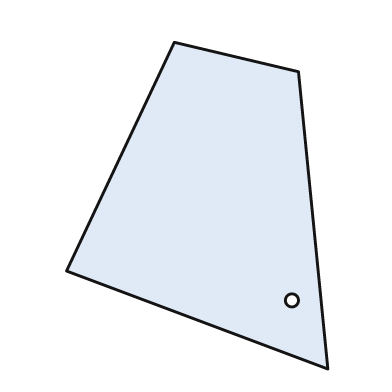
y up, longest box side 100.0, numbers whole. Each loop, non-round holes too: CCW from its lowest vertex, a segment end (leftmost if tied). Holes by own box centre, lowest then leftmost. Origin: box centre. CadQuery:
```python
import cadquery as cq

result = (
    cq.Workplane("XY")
    .moveTo(40.0, -50.0)
    .lineTo(31.0, 41.0)
    .lineTo(-7.0, 50.0)
    .lineTo(-40.0, -20.0)
    .close()
    .moveTo(29.0, -29.0)
    .circle(2.0)
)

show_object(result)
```